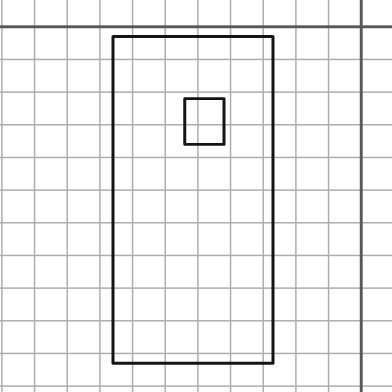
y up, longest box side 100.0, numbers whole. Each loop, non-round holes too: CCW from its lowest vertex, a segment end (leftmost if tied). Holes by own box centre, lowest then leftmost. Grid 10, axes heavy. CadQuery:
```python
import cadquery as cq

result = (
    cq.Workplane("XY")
    .moveTo(-76.0, -103.0)
    .lineTo(-27.0, -103.0)
    .lineTo(-27.0, -3.0)
    .lineTo(-76.0, -3.0)
    .close()
    .moveTo(-54.0, -36.0)
    .lineTo(-42.0, -36.0)
    .lineTo(-42.0, -22.0)
    .lineTo(-54.0, -22.0)
    .close()
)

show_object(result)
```